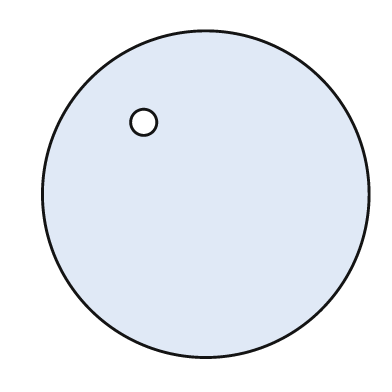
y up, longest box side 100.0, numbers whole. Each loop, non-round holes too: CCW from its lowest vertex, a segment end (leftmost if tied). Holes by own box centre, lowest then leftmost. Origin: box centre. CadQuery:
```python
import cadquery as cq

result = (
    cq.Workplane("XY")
    .moveTo(0.0, 0.0)
    .circle(50.0)
    .moveTo(-19.0, 22.0)
    .circle(4.0)
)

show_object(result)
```